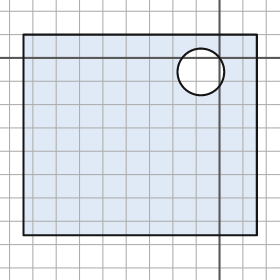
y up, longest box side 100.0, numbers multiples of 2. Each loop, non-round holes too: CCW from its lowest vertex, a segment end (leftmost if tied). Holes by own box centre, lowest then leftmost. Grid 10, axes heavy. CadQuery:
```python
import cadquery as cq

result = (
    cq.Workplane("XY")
    .moveTo(-84.0, -76.0)
    .lineTo(16.0, -76.0)
    .lineTo(16.0, 10.0)
    .lineTo(-84.0, 10.0)
    .close()
    .moveTo(-8.0, -6.0)
    .circle(10.0)
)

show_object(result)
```